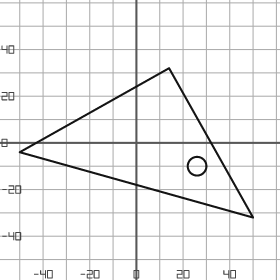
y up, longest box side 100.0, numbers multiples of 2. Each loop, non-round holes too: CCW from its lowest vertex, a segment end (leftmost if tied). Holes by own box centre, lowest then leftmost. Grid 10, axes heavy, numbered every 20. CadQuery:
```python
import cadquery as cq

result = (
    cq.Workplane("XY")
    .moveTo(50.0, -32.0)
    .lineTo(14.0, 32.0)
    .lineTo(-50.0, -4.0)
    .close()
    .moveTo(26.0, -10.0)
    .circle(4.0)
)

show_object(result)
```